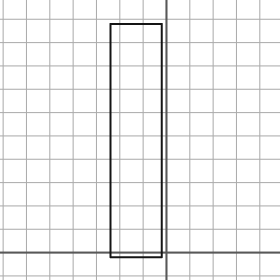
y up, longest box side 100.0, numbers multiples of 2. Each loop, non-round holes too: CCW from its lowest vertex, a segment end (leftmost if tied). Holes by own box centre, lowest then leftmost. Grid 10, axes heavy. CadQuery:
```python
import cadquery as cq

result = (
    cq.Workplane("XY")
    .moveTo(-24.0, -2.0)
    .lineTo(-2.0, -2.0)
    .lineTo(-2.0, 98.0)
    .lineTo(-24.0, 98.0)
    .close()
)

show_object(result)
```